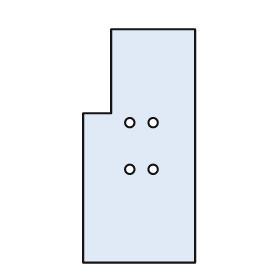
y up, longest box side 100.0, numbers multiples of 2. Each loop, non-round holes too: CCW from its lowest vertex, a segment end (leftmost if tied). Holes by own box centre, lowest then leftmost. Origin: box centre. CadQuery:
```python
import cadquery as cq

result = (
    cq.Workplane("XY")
    .moveTo(-24.0, -50.0)
    .lineTo(24.0, -50.0)
    .lineTo(24.0, 50.0)
    .lineTo(-12.0, 50.0)
    .lineTo(-12.0, 14.0)
    .lineTo(-24.0, 14.0)
    .close()
    .moveTo(-4.0, -10.0)
    .circle(2.0)
    .moveTo(6.0, -10.0)
    .circle(2.0)
    .moveTo(-4.0, 10.0)
    .circle(2.0)
    .moveTo(6.0, 10.0)
    .circle(2.0)
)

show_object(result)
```